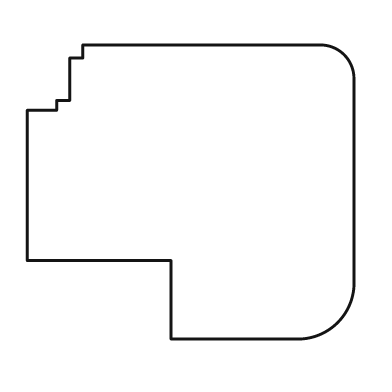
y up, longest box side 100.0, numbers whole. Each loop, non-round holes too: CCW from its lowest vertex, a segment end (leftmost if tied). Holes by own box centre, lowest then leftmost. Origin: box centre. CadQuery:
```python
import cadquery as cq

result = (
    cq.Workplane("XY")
    .moveTo(-6.0, -45.0)
    .lineTo(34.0, -45.0)
    .threePointArc((45.0, -40.0), (50.0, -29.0))
    .lineTo(50.0, 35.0)
    .threePointArc((47.0, 42.0), (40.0, 45.0))
    .lineTo(-33.0, 45.0)
    .lineTo(-33.0, 41.0)
    .lineTo(-37.0, 41.0)
    .lineTo(-37.0, 28.0)
    .lineTo(-41.0, 28.0)
    .lineTo(-41.0, 25.0)
    .lineTo(-50.0, 25.0)
    .lineTo(-50.0, -21.0)
    .lineTo(-6.0, -21.0)
    .close()
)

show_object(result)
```